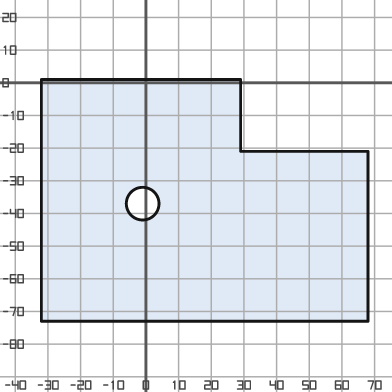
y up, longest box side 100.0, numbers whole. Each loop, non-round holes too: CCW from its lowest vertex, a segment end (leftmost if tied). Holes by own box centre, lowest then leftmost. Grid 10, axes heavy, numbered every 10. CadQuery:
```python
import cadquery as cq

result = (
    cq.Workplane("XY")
    .moveTo(-32.0, -73.0)
    .lineTo(68.0, -73.0)
    .lineTo(68.0, -21.0)
    .lineTo(29.0, -21.0)
    .lineTo(29.0, 1.0)
    .lineTo(-32.0, 1.0)
    .close()
    .moveTo(-1.0, -37.0)
    .circle(5.0)
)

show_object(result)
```